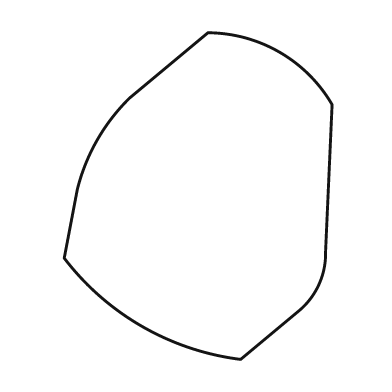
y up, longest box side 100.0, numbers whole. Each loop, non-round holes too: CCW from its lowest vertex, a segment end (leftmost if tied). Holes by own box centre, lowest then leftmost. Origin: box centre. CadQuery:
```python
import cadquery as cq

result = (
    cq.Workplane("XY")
    .moveTo(13.0, -50.0)
    .lineTo(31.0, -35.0)
    .threePointArc((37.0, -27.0), (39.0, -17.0))
    .lineTo(41.0, 28.0)
    .threePointArc((25.0, 44.0), (3.0, 50.0))
    .lineTo(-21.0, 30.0)
    .threePointArc((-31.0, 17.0), (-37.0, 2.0))
    .lineTo(-41.0, -19.0)
    .threePointArc((-17.0, -40.0), (13.0, -50.0))
    .close()
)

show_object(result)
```